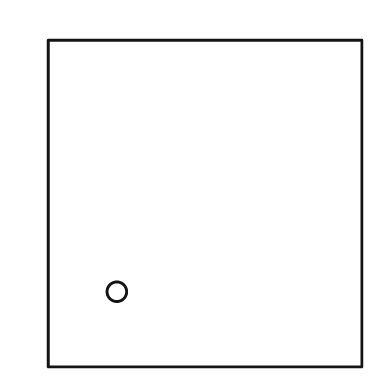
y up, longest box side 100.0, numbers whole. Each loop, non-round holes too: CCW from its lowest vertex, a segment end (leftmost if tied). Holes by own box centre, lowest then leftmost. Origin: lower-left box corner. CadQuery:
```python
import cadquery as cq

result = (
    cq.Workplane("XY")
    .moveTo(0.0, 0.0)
    .lineTo(96.0, 0.0)
    .lineTo(96.0, 100.0)
    .lineTo(0.0, 100.0)
    .close()
    .moveTo(21.0, 23.0)
    .circle(3.0)
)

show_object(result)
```